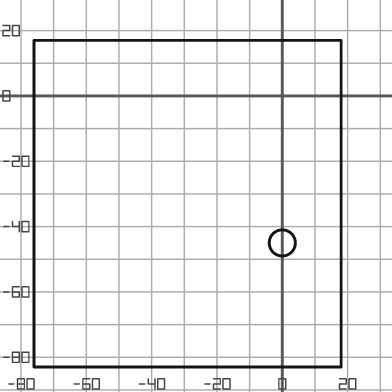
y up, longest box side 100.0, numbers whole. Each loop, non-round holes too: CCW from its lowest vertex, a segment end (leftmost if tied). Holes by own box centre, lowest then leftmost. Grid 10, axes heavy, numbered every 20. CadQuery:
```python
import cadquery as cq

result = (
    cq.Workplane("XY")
    .moveTo(-76.0, -83.0)
    .lineTo(18.0, -83.0)
    .lineTo(18.0, 17.0)
    .lineTo(-76.0, 17.0)
    .close()
    .moveTo(0.0, -45.0)
    .circle(4.0)
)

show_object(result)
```